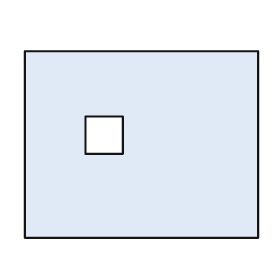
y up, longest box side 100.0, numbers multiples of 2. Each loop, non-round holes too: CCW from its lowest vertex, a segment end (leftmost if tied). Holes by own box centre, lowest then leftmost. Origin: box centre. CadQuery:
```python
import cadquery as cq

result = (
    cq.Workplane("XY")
    .moveTo(-50.0, -40.0)
    .lineTo(50.0, -40.0)
    .lineTo(50.0, 40.0)
    .lineTo(-50.0, 40.0)
    .close()
    .moveTo(-24.0, -4.0)
    .lineTo(-8.0, -4.0)
    .lineTo(-8.0, 12.0)
    .lineTo(-24.0, 12.0)
    .close()
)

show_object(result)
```